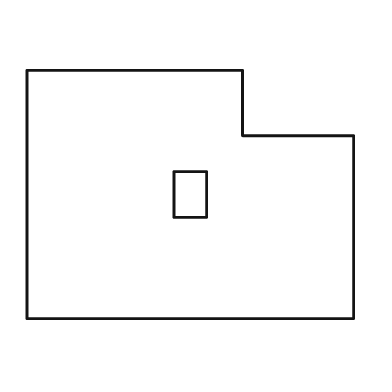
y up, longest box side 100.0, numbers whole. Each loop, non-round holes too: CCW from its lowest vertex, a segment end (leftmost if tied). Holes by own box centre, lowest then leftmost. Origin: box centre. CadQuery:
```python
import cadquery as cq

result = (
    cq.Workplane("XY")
    .moveTo(-50.0, -38.0)
    .lineTo(50.0, -38.0)
    .lineTo(50.0, 18.0)
    .lineTo(16.0, 18.0)
    .lineTo(16.0, 38.0)
    .lineTo(-50.0, 38.0)
    .close()
    .moveTo(-5.0, -7.0)
    .lineTo(5.0, -7.0)
    .lineTo(5.0, 7.0)
    .lineTo(-5.0, 7.0)
    .close()
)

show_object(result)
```